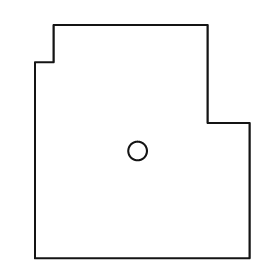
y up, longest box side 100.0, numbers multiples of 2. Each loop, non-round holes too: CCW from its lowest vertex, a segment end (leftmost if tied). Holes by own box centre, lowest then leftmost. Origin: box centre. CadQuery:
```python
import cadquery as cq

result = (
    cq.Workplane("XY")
    .moveTo(-46.0, -50.0)
    .lineTo(46.0, -50.0)
    .lineTo(46.0, 8.0)
    .lineTo(28.0, 8.0)
    .lineTo(28.0, 50.0)
    .lineTo(-38.0, 50.0)
    .lineTo(-38.0, 34.0)
    .lineTo(-46.0, 34.0)
    .close()
    .moveTo(-2.0, -4.0)
    .circle(4.0)
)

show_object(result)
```